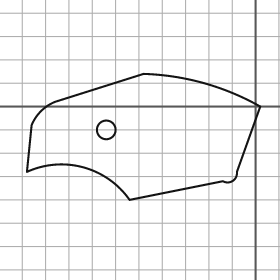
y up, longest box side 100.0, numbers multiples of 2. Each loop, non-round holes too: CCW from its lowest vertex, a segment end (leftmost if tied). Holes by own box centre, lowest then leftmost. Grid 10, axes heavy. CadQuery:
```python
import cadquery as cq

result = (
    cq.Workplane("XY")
    .moveTo(-54.0, -40.0)
    .lineTo(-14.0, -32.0)
    .threePointArc((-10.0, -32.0), (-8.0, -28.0))
    .lineTo(2.0, 0.0)
    .threePointArc((-22.0, 10.0), (-48.0, 14.0))
    .lineTo(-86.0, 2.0)
    .threePointArc((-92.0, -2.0), (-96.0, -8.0))
    .lineTo(-98.0, -28.0)
    .threePointArc((-74.0, -26.0), (-54.0, -40.0))
    .close()
    .moveTo(-64.0, -10.0)
    .circle(4.0)
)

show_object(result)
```